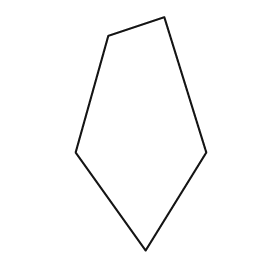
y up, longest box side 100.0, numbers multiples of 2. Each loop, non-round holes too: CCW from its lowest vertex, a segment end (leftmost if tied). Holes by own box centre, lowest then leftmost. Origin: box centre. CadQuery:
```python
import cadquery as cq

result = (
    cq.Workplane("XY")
    .moveTo(2.0, -50.0)
    .lineTo(28.0, -8.0)
    .lineTo(10.0, 50.0)
    .lineTo(-14.0, 42.0)
    .lineTo(-28.0, -8.0)
    .close()
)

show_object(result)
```